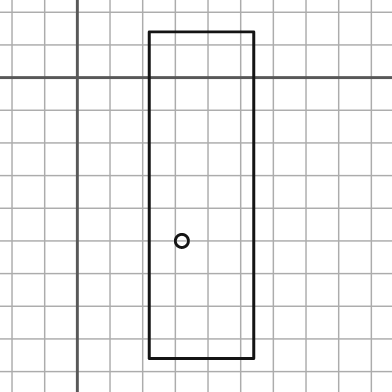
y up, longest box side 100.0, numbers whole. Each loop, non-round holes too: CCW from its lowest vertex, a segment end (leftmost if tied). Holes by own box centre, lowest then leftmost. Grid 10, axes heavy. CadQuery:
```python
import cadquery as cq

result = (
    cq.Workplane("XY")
    .moveTo(22.0, -86.0)
    .lineTo(54.0, -86.0)
    .lineTo(54.0, 14.0)
    .lineTo(22.0, 14.0)
    .close()
    .moveTo(32.0, -50.0)
    .circle(2.0)
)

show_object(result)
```